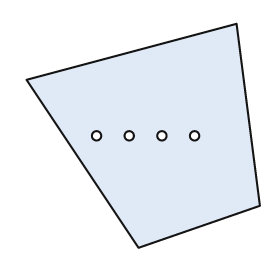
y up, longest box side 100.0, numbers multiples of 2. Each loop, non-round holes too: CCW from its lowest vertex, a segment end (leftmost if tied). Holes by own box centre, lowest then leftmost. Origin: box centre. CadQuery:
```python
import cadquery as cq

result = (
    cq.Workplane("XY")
    .moveTo(-2.0, -48.0)
    .lineTo(50.0, -30.0)
    .lineTo(40.0, 48.0)
    .lineTo(-50.0, 24.0)
    .close()
    .moveTo(-20.0, 0.0)
    .circle(2.0)
    .moveTo(-6.0, 0.0)
    .circle(2.0)
    .moveTo(8.0, 0.0)
    .circle(2.0)
    .moveTo(22.0, 0.0)
    .circle(2.0)
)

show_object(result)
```